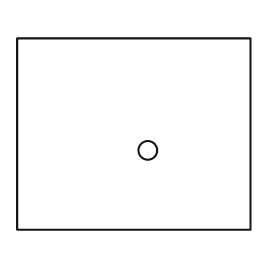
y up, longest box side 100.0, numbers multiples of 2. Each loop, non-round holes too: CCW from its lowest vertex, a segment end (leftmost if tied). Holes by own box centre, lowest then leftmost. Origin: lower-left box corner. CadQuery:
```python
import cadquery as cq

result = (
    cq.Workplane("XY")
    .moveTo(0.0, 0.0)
    .lineTo(100.0, 0.0)
    .lineTo(100.0, 82.0)
    .lineTo(0.0, 82.0)
    .close()
    .moveTo(56.0, 34.0)
    .circle(4.0)
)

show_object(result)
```